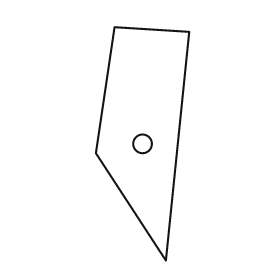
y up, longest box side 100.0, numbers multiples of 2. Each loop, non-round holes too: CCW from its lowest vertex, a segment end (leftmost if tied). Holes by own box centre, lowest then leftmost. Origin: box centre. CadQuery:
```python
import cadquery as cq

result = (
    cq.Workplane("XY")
    .moveTo(10.0, -50.0)
    .lineTo(20.0, 48.0)
    .lineTo(-12.0, 50.0)
    .lineTo(-20.0, -4.0)
    .close()
    .moveTo(0.0, 0.0)
    .circle(4.0)
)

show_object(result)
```